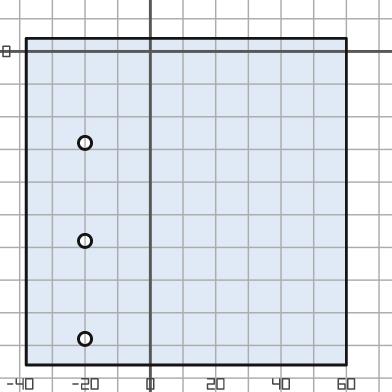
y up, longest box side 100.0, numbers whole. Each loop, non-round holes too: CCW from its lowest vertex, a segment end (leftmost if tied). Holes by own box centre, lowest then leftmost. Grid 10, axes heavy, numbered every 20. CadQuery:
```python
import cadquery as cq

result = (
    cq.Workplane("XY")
    .moveTo(-38.0, -96.0)
    .lineTo(60.0, -96.0)
    .lineTo(60.0, 4.0)
    .lineTo(-38.0, 4.0)
    .close()
    .moveTo(-20.0, -88.0)
    .circle(2.0)
    .moveTo(-20.0, -58.0)
    .circle(2.0)
    .moveTo(-20.0, -28.0)
    .circle(2.0)
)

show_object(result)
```